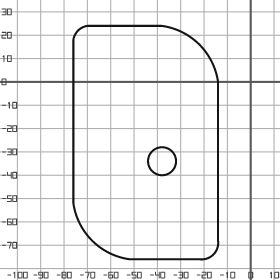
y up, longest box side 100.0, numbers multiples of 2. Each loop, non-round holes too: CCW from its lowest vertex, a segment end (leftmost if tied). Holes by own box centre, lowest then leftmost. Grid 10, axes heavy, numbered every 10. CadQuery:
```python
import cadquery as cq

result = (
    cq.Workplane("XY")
    .moveTo(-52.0, -76.0)
    .lineTo(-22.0, -76.0)
    .threePointArc((-16.0, -74.0), (-14.0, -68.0))
    .lineTo(-14.0, 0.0)
    .threePointArc((-22.0, 16.0), (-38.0, 24.0))
    .lineTo(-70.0, 24.0)
    .threePointArc((-74.0, 22.0), (-76.0, 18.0))
    .lineTo(-76.0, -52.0)
    .threePointArc((-68.0, -68.0), (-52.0, -76.0))
    .close()
    .moveTo(-38.0, -34.0)
    .circle(6.0)
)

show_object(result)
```